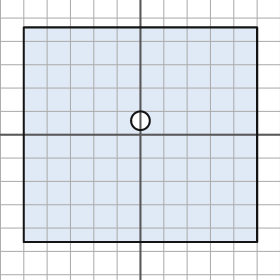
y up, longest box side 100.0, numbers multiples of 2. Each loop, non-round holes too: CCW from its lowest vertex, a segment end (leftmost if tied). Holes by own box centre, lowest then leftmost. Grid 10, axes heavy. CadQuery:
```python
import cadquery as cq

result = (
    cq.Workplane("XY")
    .moveTo(-50.0, -46.0)
    .lineTo(50.0, -46.0)
    .lineTo(50.0, 46.0)
    .lineTo(-50.0, 46.0)
    .close()
    .moveTo(0.0, 6.0)
    .circle(4.0)
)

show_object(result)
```